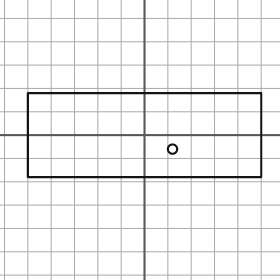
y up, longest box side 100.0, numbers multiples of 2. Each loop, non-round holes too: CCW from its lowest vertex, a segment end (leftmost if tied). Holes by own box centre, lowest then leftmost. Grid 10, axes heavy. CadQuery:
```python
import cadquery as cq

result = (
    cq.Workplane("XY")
    .moveTo(-50.0, -18.0)
    .lineTo(50.0, -18.0)
    .lineTo(50.0, 18.0)
    .lineTo(-50.0, 18.0)
    .close()
    .moveTo(12.0, -6.0)
    .circle(2.0)
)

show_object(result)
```